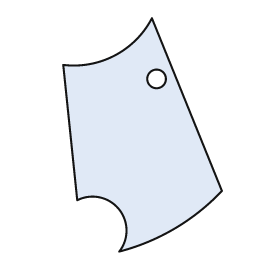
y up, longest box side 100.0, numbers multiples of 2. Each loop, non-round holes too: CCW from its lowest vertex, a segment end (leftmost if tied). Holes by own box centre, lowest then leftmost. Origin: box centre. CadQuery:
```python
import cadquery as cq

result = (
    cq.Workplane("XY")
    .moveTo(-10.0, -50.0)
    .threePointArc((14.0, -40.0), (34.0, -24.0))
    .lineTo(4.0, 50.0)
    .threePointArc((-12.0, 34.0), (-34.0, 30.0))
    .lineTo(-28.0, -28.0)
    .threePointArc((-10.0, -32.0), (-10.0, -50.0))
    .close()
    .moveTo(6.0, 24.0)
    .circle(4.0)
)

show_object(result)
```